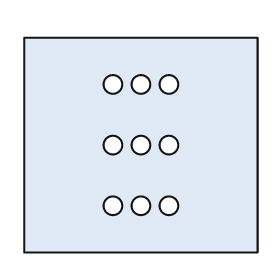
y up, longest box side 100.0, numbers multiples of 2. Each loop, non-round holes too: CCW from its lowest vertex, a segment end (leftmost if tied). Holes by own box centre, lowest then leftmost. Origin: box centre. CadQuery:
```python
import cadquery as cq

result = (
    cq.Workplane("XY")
    .moveTo(-50.0, -46.0)
    .lineTo(50.0, -46.0)
    .lineTo(50.0, 46.0)
    .lineTo(-50.0, 46.0)
    .close()
    .moveTo(-12.0, -26.0)
    .circle(4.0)
    .moveTo(0.0, -26.0)
    .circle(4.0)
    .moveTo(12.0, -26.0)
    .circle(4.0)
    .moveTo(-12.0, 0.0)
    .circle(4.0)
    .moveTo(0.0, 0.0)
    .circle(4.0)
    .moveTo(12.0, 0.0)
    .circle(4.0)
    .moveTo(-12.0, 26.0)
    .circle(4.0)
    .moveTo(0.0, 26.0)
    .circle(4.0)
    .moveTo(12.0, 26.0)
    .circle(4.0)
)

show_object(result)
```